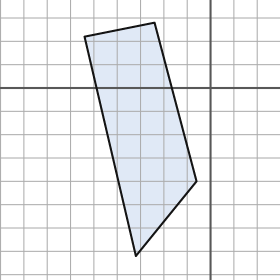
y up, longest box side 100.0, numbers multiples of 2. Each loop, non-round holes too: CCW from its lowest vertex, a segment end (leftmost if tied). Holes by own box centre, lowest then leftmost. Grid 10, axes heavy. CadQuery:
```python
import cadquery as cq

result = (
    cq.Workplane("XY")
    .moveTo(-32.0, -72.0)
    .lineTo(-6.0, -40.0)
    .lineTo(-24.0, 28.0)
    .lineTo(-54.0, 22.0)
    .close()
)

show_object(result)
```